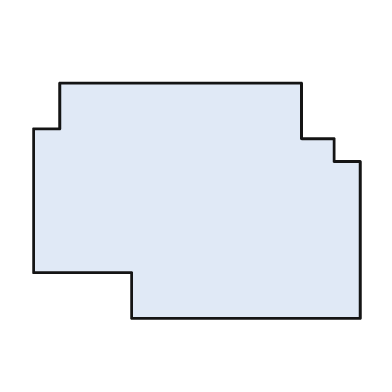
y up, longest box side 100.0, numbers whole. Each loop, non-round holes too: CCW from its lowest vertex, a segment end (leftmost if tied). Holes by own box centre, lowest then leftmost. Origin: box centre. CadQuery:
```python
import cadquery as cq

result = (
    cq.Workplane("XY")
    .moveTo(-20.0, -36.0)
    .lineTo(50.0, -36.0)
    .lineTo(50.0, 12.0)
    .lineTo(42.0, 12.0)
    .lineTo(42.0, 19.0)
    .lineTo(32.0, 19.0)
    .lineTo(32.0, 36.0)
    .lineTo(-42.0, 36.0)
    .lineTo(-42.0, 22.0)
    .lineTo(-50.0, 22.0)
    .lineTo(-50.0, -22.0)
    .lineTo(-20.0, -22.0)
    .close()
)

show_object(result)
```